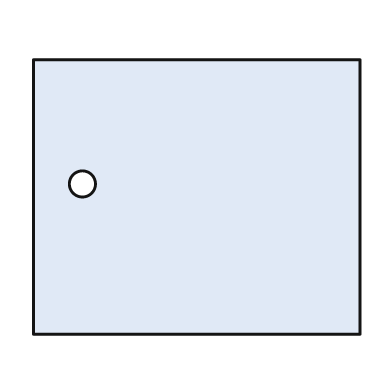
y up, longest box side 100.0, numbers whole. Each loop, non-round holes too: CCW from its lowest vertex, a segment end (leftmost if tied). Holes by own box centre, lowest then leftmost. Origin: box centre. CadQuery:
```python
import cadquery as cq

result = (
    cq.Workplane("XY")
    .moveTo(-50.0, -42.0)
    .lineTo(50.0, -42.0)
    .lineTo(50.0, 42.0)
    .lineTo(-50.0, 42.0)
    .close()
    .moveTo(-35.0, 4.0)
    .circle(4.0)
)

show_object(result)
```